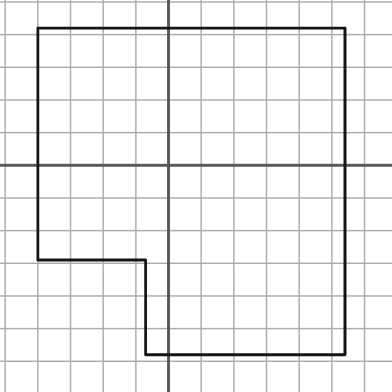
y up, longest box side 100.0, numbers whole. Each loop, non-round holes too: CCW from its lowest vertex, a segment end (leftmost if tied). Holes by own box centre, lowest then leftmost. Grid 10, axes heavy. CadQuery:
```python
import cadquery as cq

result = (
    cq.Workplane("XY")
    .moveTo(-7.0, -58.0)
    .lineTo(54.0, -58.0)
    .lineTo(54.0, 42.0)
    .lineTo(-40.0, 42.0)
    .lineTo(-40.0, -29.0)
    .lineTo(-7.0, -29.0)
    .close()
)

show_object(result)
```